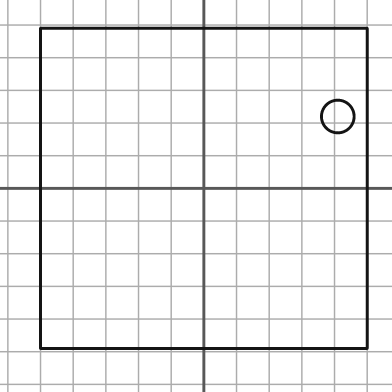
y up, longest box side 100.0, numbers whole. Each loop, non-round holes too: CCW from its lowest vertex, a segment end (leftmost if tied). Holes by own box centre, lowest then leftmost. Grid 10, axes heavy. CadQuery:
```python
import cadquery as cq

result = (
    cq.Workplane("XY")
    .moveTo(-50.0, -49.0)
    .lineTo(50.0, -49.0)
    .lineTo(50.0, 49.0)
    .lineTo(-50.0, 49.0)
    .close()
    .moveTo(41.0, 22.0)
    .circle(5.0)
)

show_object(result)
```